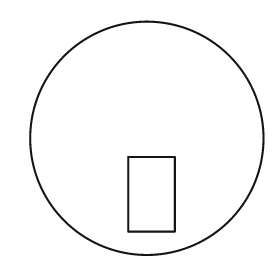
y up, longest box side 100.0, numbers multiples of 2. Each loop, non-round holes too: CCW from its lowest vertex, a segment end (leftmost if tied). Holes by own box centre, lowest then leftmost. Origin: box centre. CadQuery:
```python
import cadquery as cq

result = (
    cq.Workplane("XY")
    .moveTo(0.0, 0.0)
    .circle(50.0)
    .moveTo(-8.0, -40.0)
    .lineTo(12.0, -40.0)
    .lineTo(12.0, -8.0)
    .lineTo(-8.0, -8.0)
    .close()
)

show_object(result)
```